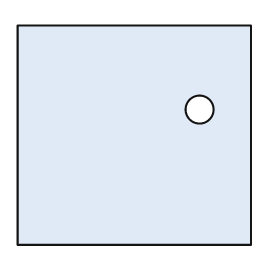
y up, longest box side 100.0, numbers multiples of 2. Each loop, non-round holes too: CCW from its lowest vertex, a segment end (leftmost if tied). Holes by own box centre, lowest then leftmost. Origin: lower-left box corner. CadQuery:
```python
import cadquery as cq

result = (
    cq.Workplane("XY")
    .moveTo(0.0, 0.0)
    .lineTo(100.0, 0.0)
    .lineTo(100.0, 94.0)
    .lineTo(0.0, 94.0)
    .close()
    .moveTo(78.0, 58.0)
    .circle(6.0)
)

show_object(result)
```